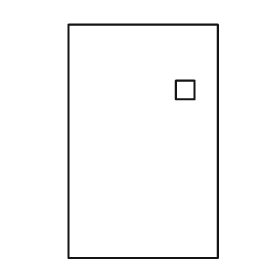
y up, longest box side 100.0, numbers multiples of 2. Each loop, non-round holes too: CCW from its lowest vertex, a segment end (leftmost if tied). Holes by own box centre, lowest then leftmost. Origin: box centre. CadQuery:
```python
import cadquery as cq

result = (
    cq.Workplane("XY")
    .moveTo(-32.0, -50.0)
    .lineTo(32.0, -50.0)
    .lineTo(32.0, 50.0)
    .lineTo(-32.0, 50.0)
    .close()
    .moveTo(14.0, 18.0)
    .lineTo(22.0, 18.0)
    .lineTo(22.0, 26.0)
    .lineTo(14.0, 26.0)
    .close()
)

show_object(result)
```